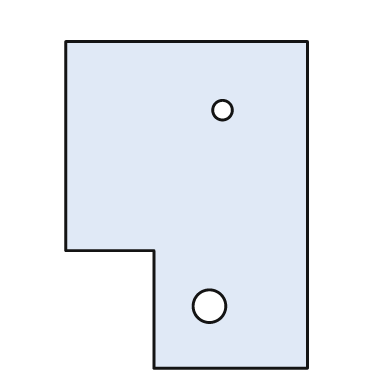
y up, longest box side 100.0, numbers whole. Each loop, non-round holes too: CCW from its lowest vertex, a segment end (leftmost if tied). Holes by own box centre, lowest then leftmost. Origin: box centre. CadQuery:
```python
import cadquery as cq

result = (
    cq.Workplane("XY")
    .moveTo(-10.0, -50.0)
    .lineTo(37.0, -50.0)
    .lineTo(37.0, 50.0)
    .lineTo(-37.0, 50.0)
    .lineTo(-37.0, -14.0)
    .lineTo(-10.0, -14.0)
    .close()
    .moveTo(7.0, -31.0)
    .circle(5.0)
    .moveTo(11.0, 29.0)
    .circle(3.0)
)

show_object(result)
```